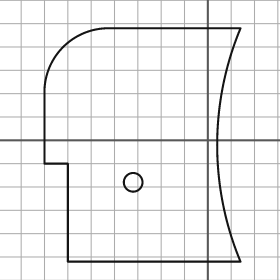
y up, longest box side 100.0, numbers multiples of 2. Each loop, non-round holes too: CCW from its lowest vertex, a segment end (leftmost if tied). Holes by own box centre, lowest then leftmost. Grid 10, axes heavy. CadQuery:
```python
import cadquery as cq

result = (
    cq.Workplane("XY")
    .moveTo(-60.0, -52.0)
    .lineTo(14.0, -52.0)
    .threePointArc((4.0, -2.0), (14.0, 48.0))
    .lineTo(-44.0, 48.0)
    .threePointArc((-62.0, 40.0), (-70.0, 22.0))
    .lineTo(-70.0, -10.0)
    .lineTo(-60.0, -10.0)
    .close()
    .moveTo(-32.0, -18.0)
    .circle(4.0)
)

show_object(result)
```